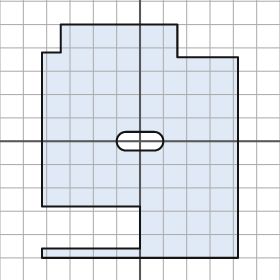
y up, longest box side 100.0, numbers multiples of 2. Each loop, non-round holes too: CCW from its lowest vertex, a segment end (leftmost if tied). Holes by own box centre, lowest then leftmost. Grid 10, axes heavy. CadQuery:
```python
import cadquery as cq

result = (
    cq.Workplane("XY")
    .moveTo(-42.0, -50.0)
    .lineTo(42.0, -50.0)
    .lineTo(42.0, 36.0)
    .lineTo(16.0, 36.0)
    .lineTo(16.0, 50.0)
    .lineTo(-34.0, 50.0)
    .lineTo(-34.0, 38.0)
    .lineTo(-42.0, 38.0)
    .lineTo(-42.0, -28.0)
    .lineTo(0.0, -28.0)
    .lineTo(0.0, -46.0)
    .lineTo(-42.0, -46.0)
    .close()
    .moveTo(-6.0, -4.0)
    .lineTo(6.0, -4.0)
    .threePointArc((10.0, 0.0), (6.0, 4.0))
    .lineTo(-6.0, 4.0)
    .threePointArc((-10.0, 0.0), (-6.0, -4.0))
    .close()
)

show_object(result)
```